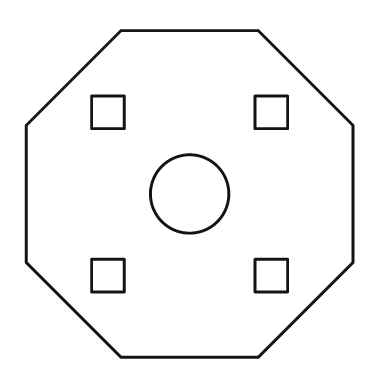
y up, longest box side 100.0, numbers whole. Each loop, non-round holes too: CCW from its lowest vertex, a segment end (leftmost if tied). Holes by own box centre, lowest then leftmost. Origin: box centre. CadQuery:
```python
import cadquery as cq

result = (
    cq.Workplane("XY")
    .moveTo(-21.0, -50.0)
    .lineTo(21.0, -50.0)
    .lineTo(50.0, -21.0)
    .lineTo(50.0, 21.0)
    .lineTo(21.0, 50.0)
    .lineTo(-21.0, 50.0)
    .lineTo(-50.0, 21.0)
    .lineTo(-50.0, -21.0)
    .close()
    .moveTo(-30.0, -30.0)
    .lineTo(-20.0, -30.0)
    .lineTo(-20.0, -20.0)
    .lineTo(-30.0, -20.0)
    .close()
    .moveTo(20.0, -30.0)
    .lineTo(30.0, -30.0)
    .lineTo(30.0, -20.0)
    .lineTo(20.0, -20.0)
    .close()
    .moveTo(0.0, 0.0)
    .circle(12.0)
    .moveTo(-30.0, 20.0)
    .lineTo(-20.0, 20.0)
    .lineTo(-20.0, 30.0)
    .lineTo(-30.0, 30.0)
    .close()
    .moveTo(20.0, 20.0)
    .lineTo(30.0, 20.0)
    .lineTo(30.0, 30.0)
    .lineTo(20.0, 30.0)
    .close()
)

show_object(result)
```